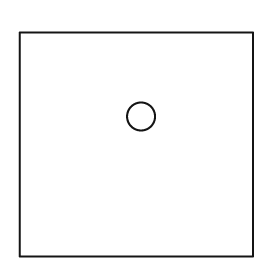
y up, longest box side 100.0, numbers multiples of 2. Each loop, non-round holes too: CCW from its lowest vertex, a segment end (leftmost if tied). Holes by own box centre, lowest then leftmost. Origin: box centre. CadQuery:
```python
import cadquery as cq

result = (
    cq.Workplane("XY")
    .moveTo(-50.0, -48.0)
    .lineTo(50.0, -48.0)
    .lineTo(50.0, 48.0)
    .lineTo(-50.0, 48.0)
    .close()
    .moveTo(2.0, 12.0)
    .circle(6.0)
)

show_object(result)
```